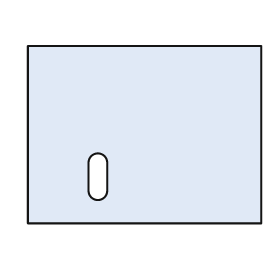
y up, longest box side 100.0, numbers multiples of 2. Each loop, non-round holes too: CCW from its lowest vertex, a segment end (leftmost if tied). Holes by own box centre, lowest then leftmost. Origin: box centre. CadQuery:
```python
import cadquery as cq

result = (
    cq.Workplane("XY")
    .moveTo(-50.0, -38.0)
    .lineTo(50.0, -38.0)
    .lineTo(50.0, 38.0)
    .lineTo(-50.0, 38.0)
    .close()
    .moveTo(-24.0, -24.0)
    .threePointArc((-20.0, -28.0), (-16.0, -24.0))
    .lineTo(-16.0, -12.0)
    .threePointArc((-20.0, -8.0), (-24.0, -12.0))
    .close()
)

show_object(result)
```